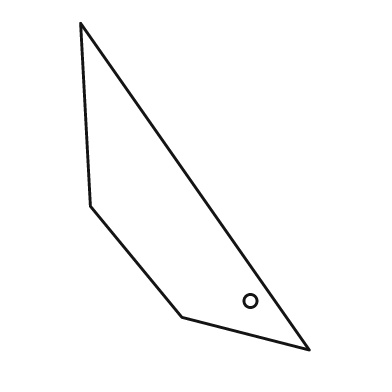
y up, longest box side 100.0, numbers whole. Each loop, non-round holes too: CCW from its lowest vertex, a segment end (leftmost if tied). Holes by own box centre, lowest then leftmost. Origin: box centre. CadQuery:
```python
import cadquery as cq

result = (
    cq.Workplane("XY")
    .moveTo(35.0, -50.0)
    .lineTo(-35.0, 50.0)
    .lineTo(-32.0, -6.0)
    .lineTo(-4.0, -40.0)
    .close()
    .moveTo(17.0, -35.0)
    .circle(2.0)
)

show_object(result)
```